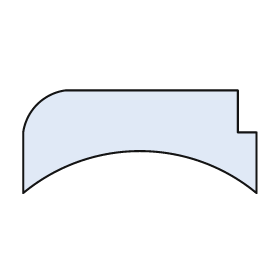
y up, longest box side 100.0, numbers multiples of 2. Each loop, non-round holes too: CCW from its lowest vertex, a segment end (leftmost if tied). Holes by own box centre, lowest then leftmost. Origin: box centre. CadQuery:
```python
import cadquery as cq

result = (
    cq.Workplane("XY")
    .moveTo(-50.0, -22.0)
    .threePointArc((0.0, -4.0), (50.0, -22.0))
    .lineTo(50.0, 4.0)
    .lineTo(42.0, 4.0)
    .lineTo(42.0, 22.0)
    .lineTo(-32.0, 22.0)
    .threePointArc((-44.0, 16.0), (-50.0, 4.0))
    .close()
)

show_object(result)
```